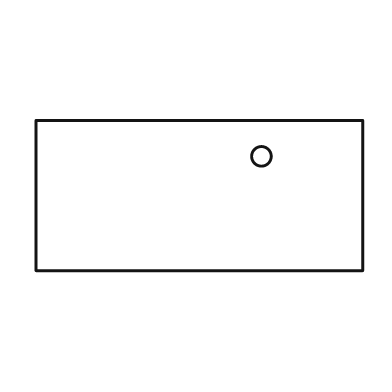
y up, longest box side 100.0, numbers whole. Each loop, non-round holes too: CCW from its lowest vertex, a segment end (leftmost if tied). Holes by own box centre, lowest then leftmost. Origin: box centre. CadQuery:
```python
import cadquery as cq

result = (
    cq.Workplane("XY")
    .moveTo(-50.0, -23.0)
    .lineTo(50.0, -23.0)
    .lineTo(50.0, 23.0)
    .lineTo(-50.0, 23.0)
    .close()
    .moveTo(19.0, 12.0)
    .circle(3.0)
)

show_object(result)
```